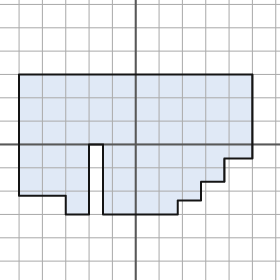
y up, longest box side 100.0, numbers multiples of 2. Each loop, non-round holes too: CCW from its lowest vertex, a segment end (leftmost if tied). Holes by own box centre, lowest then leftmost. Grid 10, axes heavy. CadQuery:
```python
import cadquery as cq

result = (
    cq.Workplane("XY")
    .moveTo(-30.0, -30.0)
    .lineTo(-20.0, -30.0)
    .lineTo(-20.0, 0.0)
    .lineTo(-14.0, 0.0)
    .lineTo(-14.0, -30.0)
    .lineTo(18.0, -30.0)
    .lineTo(18.0, -24.0)
    .lineTo(28.0, -24.0)
    .lineTo(28.0, -16.0)
    .lineTo(38.0, -16.0)
    .lineTo(38.0, -6.0)
    .lineTo(50.0, -6.0)
    .lineTo(50.0, 30.0)
    .lineTo(-50.0, 30.0)
    .lineTo(-50.0, -22.0)
    .lineTo(-30.0, -22.0)
    .close()
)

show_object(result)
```